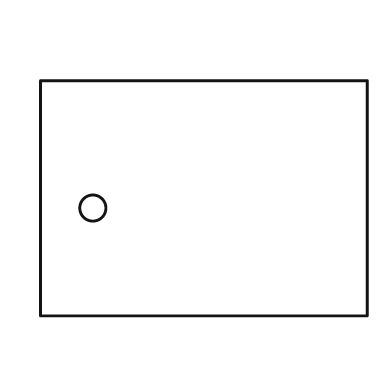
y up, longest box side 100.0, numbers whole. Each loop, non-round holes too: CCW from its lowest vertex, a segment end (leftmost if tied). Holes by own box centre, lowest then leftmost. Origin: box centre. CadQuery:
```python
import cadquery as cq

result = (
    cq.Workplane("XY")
    .moveTo(-50.0, -36.0)
    .lineTo(50.0, -36.0)
    .lineTo(50.0, 36.0)
    .lineTo(-50.0, 36.0)
    .close()
    .moveTo(-34.0, -3.0)
    .circle(4.0)
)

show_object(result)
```